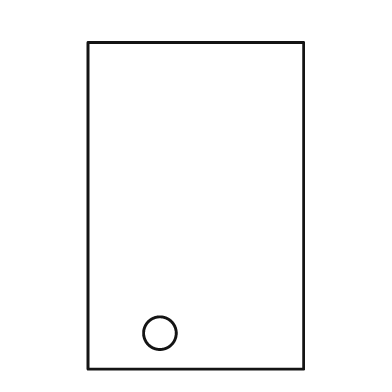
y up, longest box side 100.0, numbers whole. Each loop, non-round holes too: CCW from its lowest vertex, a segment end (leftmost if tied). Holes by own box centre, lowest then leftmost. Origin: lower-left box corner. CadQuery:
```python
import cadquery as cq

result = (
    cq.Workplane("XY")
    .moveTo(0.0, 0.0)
    .lineTo(66.0, 0.0)
    .lineTo(66.0, 100.0)
    .lineTo(0.0, 100.0)
    .close()
    .moveTo(22.0, 11.0)
    .circle(5.0)
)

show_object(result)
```